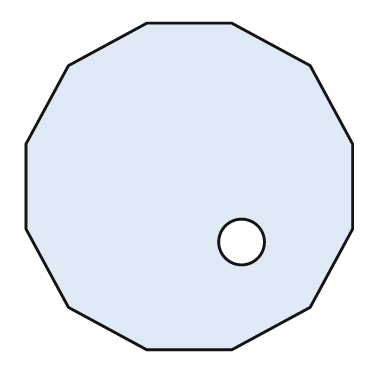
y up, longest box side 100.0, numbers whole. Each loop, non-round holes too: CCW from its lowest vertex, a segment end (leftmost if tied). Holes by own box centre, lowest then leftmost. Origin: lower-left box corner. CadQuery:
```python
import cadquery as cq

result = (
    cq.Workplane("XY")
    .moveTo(37.0, 0.0)
    .lineTo(63.0, 0.0)
    .lineTo(87.0, 13.0)
    .lineTo(100.0, 37.0)
    .lineTo(100.0, 63.0)
    .lineTo(87.0, 87.0)
    .lineTo(63.0, 100.0)
    .lineTo(37.0, 100.0)
    .lineTo(13.0, 87.0)
    .lineTo(0.0, 63.0)
    .lineTo(0.0, 37.0)
    .lineTo(13.0, 13.0)
    .close()
    .moveTo(66.0, 33.0)
    .circle(7.0)
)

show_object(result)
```